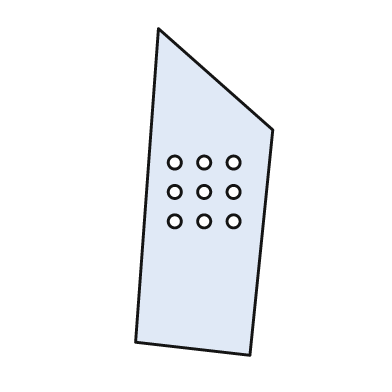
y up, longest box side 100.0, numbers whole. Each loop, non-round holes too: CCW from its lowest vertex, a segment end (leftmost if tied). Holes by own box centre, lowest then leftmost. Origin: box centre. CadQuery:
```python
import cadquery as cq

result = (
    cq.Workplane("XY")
    .moveTo(14.0, -50.0)
    .lineTo(21.0, 19.0)
    .lineTo(-14.0, 50.0)
    .lineTo(-21.0, -46.0)
    .close()
    .moveTo(-9.0, -9.0)
    .circle(2.0)
    .moveTo(0.0, -9.0)
    .circle(2.0)
    .moveTo(9.0, -9.0)
    .circle(2.0)
    .moveTo(-9.0, 0.0)
    .circle(2.0)
    .moveTo(0.0, 0.0)
    .circle(2.0)
    .moveTo(9.0, 0.0)
    .circle(2.0)
    .moveTo(-9.0, 9.0)
    .circle(2.0)
    .moveTo(0.0, 9.0)
    .circle(2.0)
    .moveTo(9.0, 9.0)
    .circle(2.0)
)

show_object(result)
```